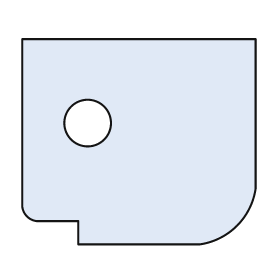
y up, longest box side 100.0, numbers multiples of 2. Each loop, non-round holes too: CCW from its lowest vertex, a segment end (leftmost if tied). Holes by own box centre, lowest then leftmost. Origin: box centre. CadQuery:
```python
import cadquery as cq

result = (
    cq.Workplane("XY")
    .moveTo(-26.0, -44.0)
    .lineTo(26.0, -44.0)
    .threePointArc((42.0, -36.0), (50.0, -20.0))
    .lineTo(50.0, 44.0)
    .lineTo(-50.0, 44.0)
    .lineTo(-50.0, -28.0)
    .threePointArc((-48.0, -32.0), (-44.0, -34.0))
    .lineTo(-26.0, -34.0)
    .close()
    .moveTo(-22.0, 8.0)
    .circle(10.0)
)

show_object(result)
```